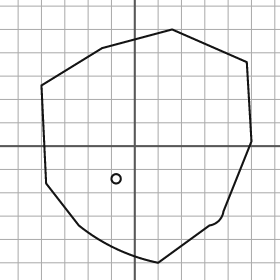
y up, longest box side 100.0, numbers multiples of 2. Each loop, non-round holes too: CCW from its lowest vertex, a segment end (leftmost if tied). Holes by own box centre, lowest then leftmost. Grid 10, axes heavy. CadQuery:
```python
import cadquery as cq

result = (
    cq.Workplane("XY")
    .moveTo(10.0, -50.0)
    .lineTo(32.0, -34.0)
    .threePointArc((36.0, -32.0), (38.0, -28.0))
    .lineTo(50.0, 2.0)
    .lineTo(48.0, 36.0)
    .lineTo(16.0, 50.0)
    .lineTo(-14.0, 42.0)
    .lineTo(-40.0, 26.0)
    .lineTo(-38.0, -16.0)
    .lineTo(-24.0, -34.0)
    .threePointArc((-8.0, -44.0), (10.0, -50.0))
    .close()
    .moveTo(-8.0, -14.0)
    .circle(2.0)
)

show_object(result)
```